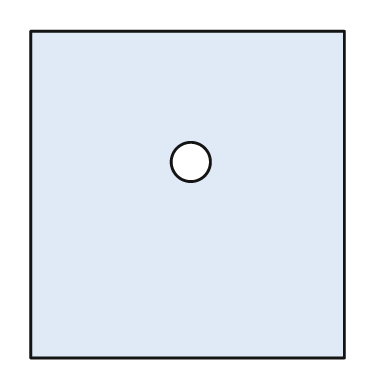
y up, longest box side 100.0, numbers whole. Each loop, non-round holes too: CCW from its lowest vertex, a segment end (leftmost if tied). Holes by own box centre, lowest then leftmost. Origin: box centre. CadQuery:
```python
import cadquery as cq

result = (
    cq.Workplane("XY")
    .moveTo(-48.0, -50.0)
    .lineTo(48.0, -50.0)
    .lineTo(48.0, 50.0)
    .lineTo(-48.0, 50.0)
    .close()
    .moveTo(1.0, 10.0)
    .circle(6.0)
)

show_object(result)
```